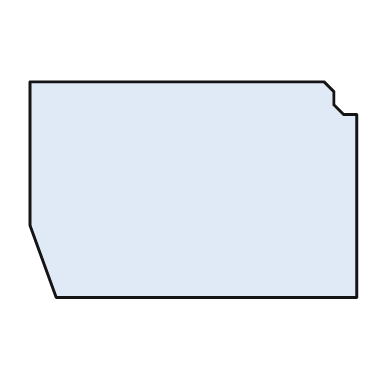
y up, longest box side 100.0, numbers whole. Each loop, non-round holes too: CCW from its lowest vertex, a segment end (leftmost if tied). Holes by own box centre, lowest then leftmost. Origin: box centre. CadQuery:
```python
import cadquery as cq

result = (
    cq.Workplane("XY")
    .moveTo(-42.0, -33.0)
    .lineTo(50.0, -33.0)
    .lineTo(50.0, 23.0)
    .lineTo(46.0, 23.0)
    .lineTo(43.0, 26.0)
    .lineTo(43.0, 30.0)
    .lineTo(40.0, 33.0)
    .lineTo(-50.0, 33.0)
    .lineTo(-50.0, -11.0)
    .close()
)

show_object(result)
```